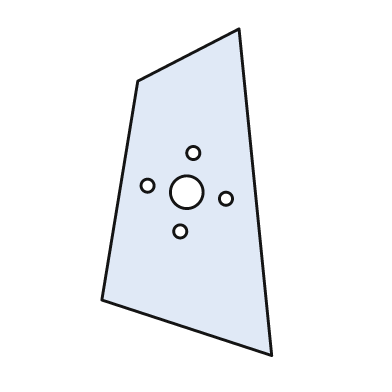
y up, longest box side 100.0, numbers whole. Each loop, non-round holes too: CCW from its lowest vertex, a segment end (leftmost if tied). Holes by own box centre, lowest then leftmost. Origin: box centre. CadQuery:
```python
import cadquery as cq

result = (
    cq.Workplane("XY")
    .moveTo(26.0, -50.0)
    .lineTo(16.0, 50.0)
    .lineTo(-15.0, 34.0)
    .lineTo(-26.0, -33.0)
    .close()
    .moveTo(-2.0, -12.0)
    .circle(2.0)
    .moveTo(12.0, -2.0)
    .circle(2.0)
    .moveTo(0.0, 0.0)
    .circle(5.0)
    .moveTo(-12.0, 2.0)
    .circle(2.0)
    .moveTo(2.0, 12.0)
    .circle(2.0)
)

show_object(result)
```